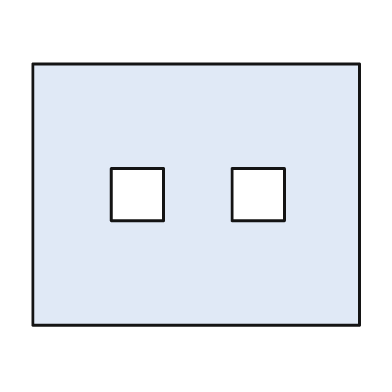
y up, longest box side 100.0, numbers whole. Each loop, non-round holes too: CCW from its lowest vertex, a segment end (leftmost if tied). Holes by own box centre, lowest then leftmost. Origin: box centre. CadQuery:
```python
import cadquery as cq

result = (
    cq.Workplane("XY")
    .moveTo(-50.0, -40.0)
    .lineTo(50.0, -40.0)
    .lineTo(50.0, 40.0)
    .lineTo(-50.0, 40.0)
    .close()
    .moveTo(-26.0, -8.0)
    .lineTo(-10.0, -8.0)
    .lineTo(-10.0, 8.0)
    .lineTo(-26.0, 8.0)
    .close()
    .moveTo(11.0, -8.0)
    .lineTo(27.0, -8.0)
    .lineTo(27.0, 8.0)
    .lineTo(11.0, 8.0)
    .close()
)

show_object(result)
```